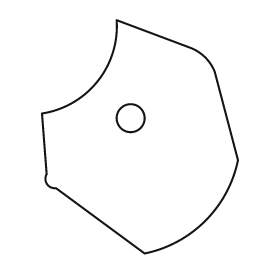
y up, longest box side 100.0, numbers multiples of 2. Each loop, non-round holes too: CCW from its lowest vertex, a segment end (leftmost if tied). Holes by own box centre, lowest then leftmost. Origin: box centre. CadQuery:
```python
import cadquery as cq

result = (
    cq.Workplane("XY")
    .moveTo(2.0, -50.0)
    .threePointArc((28.0, -36.0), (42.0, -10.0))
    .lineTo(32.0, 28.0)
    .threePointArc((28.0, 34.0), (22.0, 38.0))
    .lineTo(-10.0, 50.0)
    .threePointArc((-18.0, 24.0), (-42.0, 10.0))
    .lineTo(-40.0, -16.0)
    .threePointArc((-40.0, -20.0), (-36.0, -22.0))
    .close()
    .moveTo(-4.0, 8.0)
    .circle(6.0)
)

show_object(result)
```